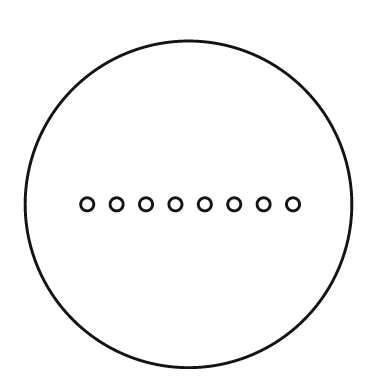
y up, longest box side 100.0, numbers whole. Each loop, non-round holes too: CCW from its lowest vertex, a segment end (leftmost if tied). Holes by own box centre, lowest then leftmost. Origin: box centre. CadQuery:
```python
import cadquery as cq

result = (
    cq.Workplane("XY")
    .moveTo(0.0, 0.0)
    .circle(50.0)
    .moveTo(-31.0, 0.0)
    .circle(2.0)
    .moveTo(-22.0, 0.0)
    .circle(2.0)
    .moveTo(-13.0, 0.0)
    .circle(2.0)
    .moveTo(-4.0, 0.0)
    .circle(2.0)
    .moveTo(5.0, 0.0)
    .circle(2.0)
    .moveTo(14.0, 0.0)
    .circle(2.0)
    .moveTo(23.0, 0.0)
    .circle(2.0)
    .moveTo(32.0, 0.0)
    .circle(2.0)
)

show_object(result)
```